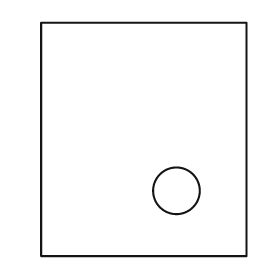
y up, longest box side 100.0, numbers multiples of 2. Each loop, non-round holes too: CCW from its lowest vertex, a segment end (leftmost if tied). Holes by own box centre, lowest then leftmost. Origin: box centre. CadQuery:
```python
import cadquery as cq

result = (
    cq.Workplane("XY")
    .moveTo(-44.0, -50.0)
    .lineTo(44.0, -50.0)
    .lineTo(44.0, 50.0)
    .lineTo(-44.0, 50.0)
    .close()
    .moveTo(14.0, -22.0)
    .circle(10.0)
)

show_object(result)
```